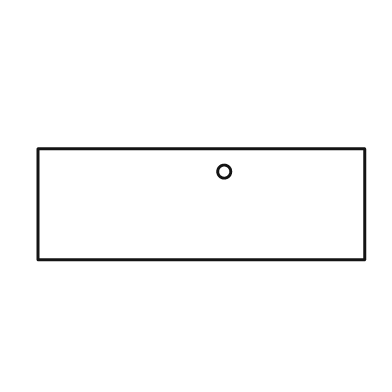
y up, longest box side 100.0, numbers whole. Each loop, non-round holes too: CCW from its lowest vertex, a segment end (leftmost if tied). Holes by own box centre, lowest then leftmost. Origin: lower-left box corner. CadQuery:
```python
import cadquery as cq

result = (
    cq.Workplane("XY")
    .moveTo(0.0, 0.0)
    .lineTo(100.0, 0.0)
    .lineTo(100.0, 34.0)
    .lineTo(0.0, 34.0)
    .close()
    .moveTo(57.0, 27.0)
    .circle(2.0)
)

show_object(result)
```